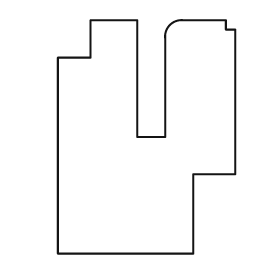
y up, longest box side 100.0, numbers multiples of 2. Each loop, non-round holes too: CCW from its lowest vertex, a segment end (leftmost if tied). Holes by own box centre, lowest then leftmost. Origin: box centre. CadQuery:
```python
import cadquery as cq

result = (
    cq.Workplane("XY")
    .moveTo(-38.0, -50.0)
    .lineTo(20.0, -50.0)
    .lineTo(20.0, -16.0)
    .lineTo(38.0, -16.0)
    .lineTo(38.0, 46.0)
    .lineTo(34.0, 46.0)
    .lineTo(34.0, 50.0)
    .lineTo(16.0, 50.0)
    .threePointArc((10.0, 48.0), (8.0, 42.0))
    .lineTo(8.0, 0.0)
    .lineTo(-4.0, 0.0)
    .lineTo(-4.0, 50.0)
    .lineTo(-24.0, 50.0)
    .lineTo(-24.0, 34.0)
    .lineTo(-38.0, 34.0)
    .close()
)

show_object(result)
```